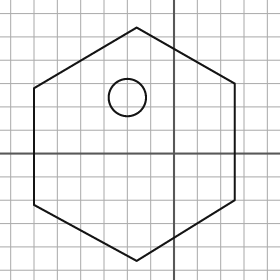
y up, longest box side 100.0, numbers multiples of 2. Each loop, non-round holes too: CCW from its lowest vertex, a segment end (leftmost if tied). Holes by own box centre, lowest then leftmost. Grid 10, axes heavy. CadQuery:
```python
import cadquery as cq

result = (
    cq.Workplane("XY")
    .moveTo(-16.0, -46.0)
    .lineTo(26.0, -20.0)
    .lineTo(26.0, 30.0)
    .lineTo(-16.0, 54.0)
    .lineTo(-60.0, 28.0)
    .lineTo(-60.0, -22.0)
    .close()
    .moveTo(-20.0, 24.0)
    .circle(8.0)
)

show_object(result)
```